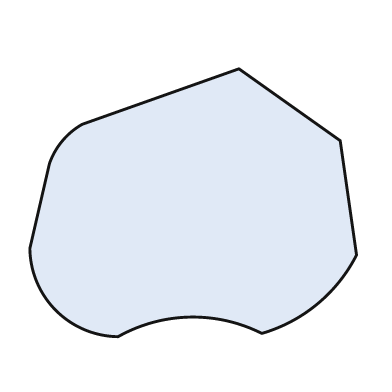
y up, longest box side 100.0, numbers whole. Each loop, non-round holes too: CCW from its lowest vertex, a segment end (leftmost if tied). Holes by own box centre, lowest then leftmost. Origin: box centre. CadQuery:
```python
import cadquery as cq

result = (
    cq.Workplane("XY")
    .moveTo(-23.0, -41.0)
    .threePointArc((-1.0, -35.0), (21.0, -40.0))
    .threePointArc((38.0, -31.0), (50.0, -16.0))
    .lineTo(45.0, 19.0)
    .lineTo(14.0, 41.0)
    .lineTo(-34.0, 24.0)
    .threePointArc((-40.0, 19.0), (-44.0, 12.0))
    .lineTo(-50.0, -14.0)
    .threePointArc((-42.0, -33.0), (-23.0, -41.0))
    .close()
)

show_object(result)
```